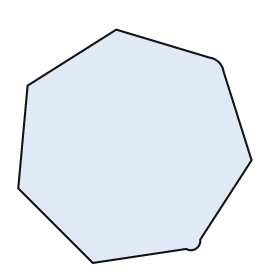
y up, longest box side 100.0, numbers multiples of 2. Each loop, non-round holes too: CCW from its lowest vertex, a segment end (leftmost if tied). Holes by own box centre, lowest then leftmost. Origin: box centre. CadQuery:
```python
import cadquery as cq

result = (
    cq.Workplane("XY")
    .moveTo(-18.0, -50.0)
    .lineTo(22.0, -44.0)
    .threePointArc((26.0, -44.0), (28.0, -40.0))
    .lineTo(50.0, -6.0)
    .lineTo(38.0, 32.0)
    .threePointArc((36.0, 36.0), (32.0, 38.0))
    .lineTo(-8.0, 50.0)
    .lineTo(-46.0, 26.0)
    .lineTo(-50.0, -18.0)
    .close()
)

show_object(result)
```